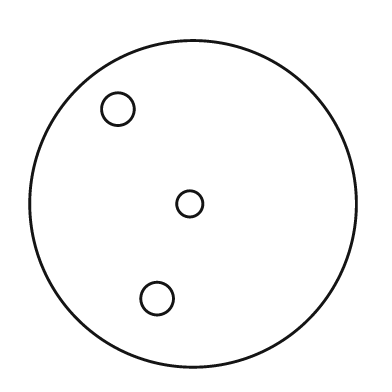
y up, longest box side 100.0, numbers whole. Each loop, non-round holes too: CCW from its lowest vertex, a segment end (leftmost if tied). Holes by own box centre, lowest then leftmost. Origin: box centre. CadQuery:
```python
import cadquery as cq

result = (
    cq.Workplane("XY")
    .moveTo(0.0, 0.0)
    .circle(50.0)
    .moveTo(-11.0, -29.0)
    .circle(5.0)
    .moveTo(-1.0, 0.0)
    .circle(4.0)
    .moveTo(-23.0, 29.0)
    .circle(5.0)
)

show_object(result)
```